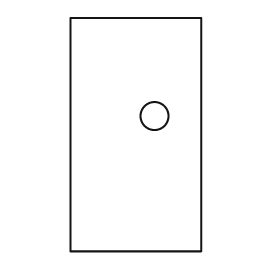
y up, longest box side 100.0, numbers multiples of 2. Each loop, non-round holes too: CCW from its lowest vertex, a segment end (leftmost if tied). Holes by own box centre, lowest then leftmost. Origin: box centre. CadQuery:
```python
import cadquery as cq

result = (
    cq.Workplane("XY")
    .moveTo(-28.0, -50.0)
    .lineTo(28.0, -50.0)
    .lineTo(28.0, 50.0)
    .lineTo(-28.0, 50.0)
    .close()
    .moveTo(8.0, 8.0)
    .circle(6.0)
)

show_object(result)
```